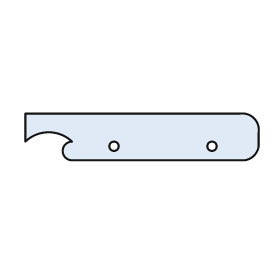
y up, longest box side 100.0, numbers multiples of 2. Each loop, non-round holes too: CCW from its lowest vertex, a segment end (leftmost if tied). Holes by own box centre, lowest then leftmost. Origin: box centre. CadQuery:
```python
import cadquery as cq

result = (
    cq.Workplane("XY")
    .moveTo(-30.0, -10.0)
    .lineTo(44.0, -10.0)
    .threePointArc((48.0, -8.0), (50.0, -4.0))
    .lineTo(50.0, 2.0)
    .threePointArc((48.0, 8.0), (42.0, 10.0))
    .lineTo(-50.0, 10.0)
    .lineTo(-50.0, -2.0)
    .threePointArc((-40.0, 2.0), (-30.0, -2.0))
    .threePointArc((-34.0, -6.0), (-30.0, -10.0))
    .close()
    .moveTo(-12.0, -4.0)
    .circle(2.0)
    .moveTo(30.0, -4.0)
    .circle(2.0)
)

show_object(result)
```